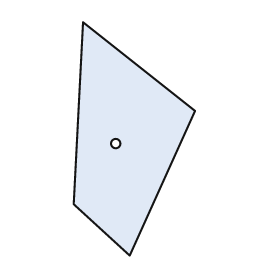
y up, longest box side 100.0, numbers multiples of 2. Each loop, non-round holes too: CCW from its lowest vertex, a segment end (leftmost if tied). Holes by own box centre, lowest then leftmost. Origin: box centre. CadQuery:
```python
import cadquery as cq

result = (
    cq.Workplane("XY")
    .moveTo(-2.0, -50.0)
    .lineTo(26.0, 12.0)
    .lineTo(-22.0, 50.0)
    .lineTo(-26.0, -28.0)
    .close()
    .moveTo(-8.0, -2.0)
    .circle(2.0)
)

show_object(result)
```